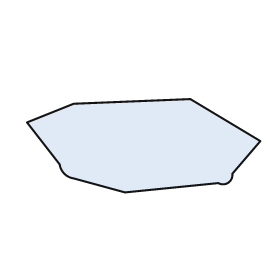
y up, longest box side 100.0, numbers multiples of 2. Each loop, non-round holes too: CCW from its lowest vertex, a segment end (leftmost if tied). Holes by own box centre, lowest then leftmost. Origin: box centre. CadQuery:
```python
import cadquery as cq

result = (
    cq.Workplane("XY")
    .moveTo(-8.0, -20.0)
    .lineTo(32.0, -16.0)
    .threePointArc((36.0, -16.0), (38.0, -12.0))
    .lineTo(50.0, 2.0)
    .lineTo(20.0, 20.0)
    .lineTo(-30.0, 18.0)
    .lineTo(-50.0, 10.0)
    .lineTo(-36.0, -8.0)
    .threePointArc((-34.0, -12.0), (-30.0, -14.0))
    .close()
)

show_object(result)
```